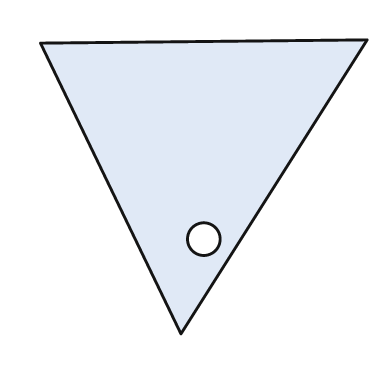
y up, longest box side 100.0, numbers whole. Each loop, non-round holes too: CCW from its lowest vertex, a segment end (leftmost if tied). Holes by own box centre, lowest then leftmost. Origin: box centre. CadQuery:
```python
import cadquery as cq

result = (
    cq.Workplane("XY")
    .moveTo(-7.0, -45.0)
    .lineTo(50.0, 45.0)
    .lineTo(-50.0, 44.0)
    .close()
    .moveTo(0.0, -16.0)
    .circle(5.0)
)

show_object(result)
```